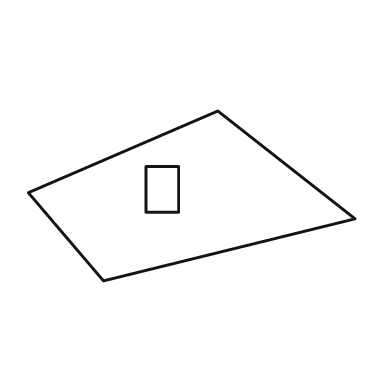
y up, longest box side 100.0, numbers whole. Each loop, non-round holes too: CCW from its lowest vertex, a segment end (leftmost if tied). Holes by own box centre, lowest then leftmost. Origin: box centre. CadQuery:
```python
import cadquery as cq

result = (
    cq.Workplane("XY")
    .moveTo(-27.0, -26.0)
    .lineTo(50.0, -7.0)
    .lineTo(8.0, 26.0)
    .lineTo(-50.0, 1.0)
    .close()
    .moveTo(-14.0, -5.0)
    .lineTo(-4.0, -5.0)
    .lineTo(-4.0, 9.0)
    .lineTo(-14.0, 9.0)
    .close()
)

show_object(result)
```